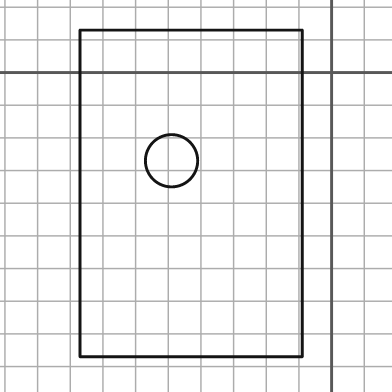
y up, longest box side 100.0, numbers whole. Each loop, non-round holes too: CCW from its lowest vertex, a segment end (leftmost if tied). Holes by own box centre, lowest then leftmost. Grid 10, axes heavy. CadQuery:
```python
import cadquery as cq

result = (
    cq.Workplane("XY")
    .moveTo(-77.0, -87.0)
    .lineTo(-9.0, -87.0)
    .lineTo(-9.0, 13.0)
    .lineTo(-77.0, 13.0)
    .close()
    .moveTo(-49.0, -27.0)
    .circle(8.0)
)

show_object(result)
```